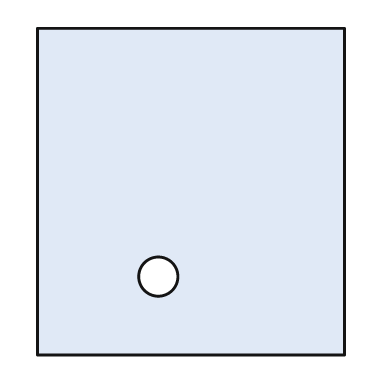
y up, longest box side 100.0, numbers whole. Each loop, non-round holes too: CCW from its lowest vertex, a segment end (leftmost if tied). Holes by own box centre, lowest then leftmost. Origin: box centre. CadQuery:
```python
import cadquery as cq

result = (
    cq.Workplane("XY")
    .moveTo(-47.0, -50.0)
    .lineTo(47.0, -50.0)
    .lineTo(47.0, 50.0)
    .lineTo(-47.0, 50.0)
    .close()
    .moveTo(-10.0, -26.0)
    .circle(6.0)
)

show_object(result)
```